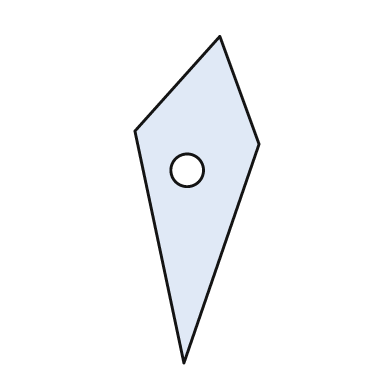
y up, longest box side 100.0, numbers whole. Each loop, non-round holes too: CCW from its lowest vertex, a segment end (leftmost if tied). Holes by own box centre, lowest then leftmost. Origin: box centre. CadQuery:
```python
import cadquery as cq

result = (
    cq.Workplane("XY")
    .moveTo(-4.0, -50.0)
    .lineTo(19.0, 17.0)
    .lineTo(7.0, 50.0)
    .lineTo(-19.0, 21.0)
    .close()
    .moveTo(-3.0, 9.0)
    .circle(5.0)
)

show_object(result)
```